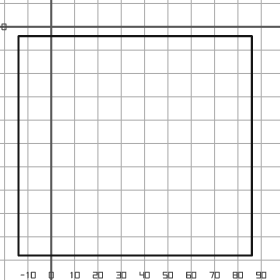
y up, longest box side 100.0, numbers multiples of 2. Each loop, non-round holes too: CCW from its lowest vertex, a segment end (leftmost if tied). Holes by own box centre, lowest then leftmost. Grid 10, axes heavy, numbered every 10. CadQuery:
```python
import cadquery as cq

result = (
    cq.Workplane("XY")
    .moveTo(-14.0, -98.0)
    .lineTo(86.0, -98.0)
    .lineTo(86.0, -4.0)
    .lineTo(-14.0, -4.0)
    .close()
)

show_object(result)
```